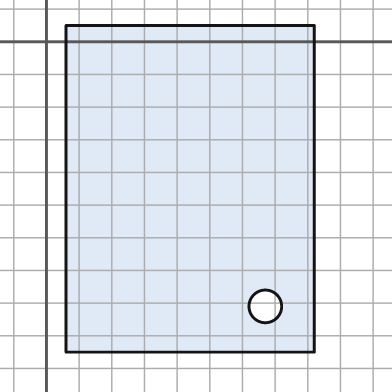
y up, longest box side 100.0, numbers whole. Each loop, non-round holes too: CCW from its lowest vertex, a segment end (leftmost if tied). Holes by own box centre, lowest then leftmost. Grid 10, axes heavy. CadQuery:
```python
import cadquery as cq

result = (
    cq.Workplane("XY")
    .moveTo(6.0, -95.0)
    .lineTo(82.0, -95.0)
    .lineTo(82.0, 5.0)
    .lineTo(6.0, 5.0)
    .close()
    .moveTo(67.0, -81.0)
    .circle(5.0)
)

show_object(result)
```